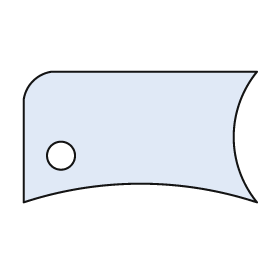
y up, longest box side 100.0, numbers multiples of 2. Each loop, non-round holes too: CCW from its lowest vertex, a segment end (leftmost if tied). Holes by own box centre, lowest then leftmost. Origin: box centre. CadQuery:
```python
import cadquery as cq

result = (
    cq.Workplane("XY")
    .moveTo(-50.0, -28.0)
    .threePointArc((0.0, -20.0), (50.0, -28.0))
    .threePointArc((40.0, 0.0), (50.0, 28.0))
    .lineTo(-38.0, 28.0)
    .threePointArc((-46.0, 24.0), (-50.0, 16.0))
    .close()
    .moveTo(-34.0, -8.0)
    .circle(6.0)
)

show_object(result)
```